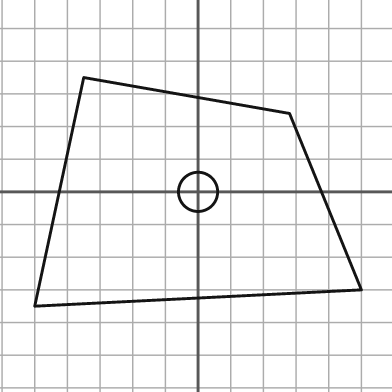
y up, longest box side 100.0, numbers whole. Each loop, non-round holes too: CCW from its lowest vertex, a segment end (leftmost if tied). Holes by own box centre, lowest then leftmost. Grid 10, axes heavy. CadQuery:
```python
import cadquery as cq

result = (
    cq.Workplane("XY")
    .moveTo(-50.0, -35.0)
    .lineTo(50.0, -30.0)
    .lineTo(28.0, 24.0)
    .lineTo(-35.0, 35.0)
    .close()
    .moveTo(0.0, 0.0)
    .circle(6.0)
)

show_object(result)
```